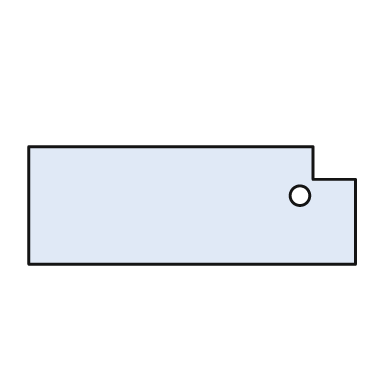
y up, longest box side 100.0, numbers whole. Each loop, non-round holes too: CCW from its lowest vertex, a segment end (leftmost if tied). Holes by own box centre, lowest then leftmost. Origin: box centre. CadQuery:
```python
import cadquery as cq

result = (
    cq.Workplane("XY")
    .moveTo(-50.0, -18.0)
    .lineTo(50.0, -18.0)
    .lineTo(50.0, 8.0)
    .lineTo(37.0, 8.0)
    .lineTo(37.0, 18.0)
    .lineTo(-50.0, 18.0)
    .close()
    .moveTo(33.0, 3.0)
    .circle(3.0)
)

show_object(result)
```